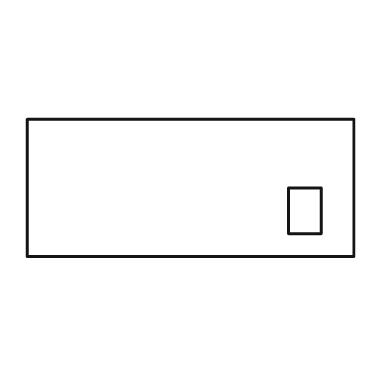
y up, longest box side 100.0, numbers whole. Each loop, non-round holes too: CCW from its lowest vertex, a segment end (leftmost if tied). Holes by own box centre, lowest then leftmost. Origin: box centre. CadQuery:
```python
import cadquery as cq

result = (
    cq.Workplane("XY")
    .moveTo(-50.0, -21.0)
    .lineTo(50.0, -21.0)
    .lineTo(50.0, 21.0)
    .lineTo(-50.0, 21.0)
    .close()
    .moveTo(30.0, -14.0)
    .lineTo(40.0, -14.0)
    .lineTo(40.0, 0.0)
    .lineTo(30.0, 0.0)
    .close()
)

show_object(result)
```